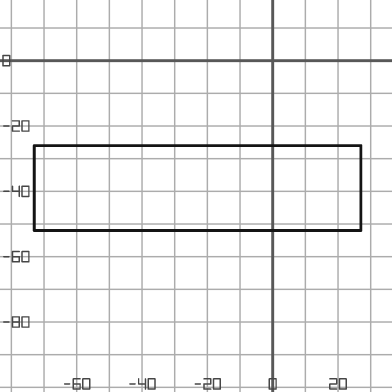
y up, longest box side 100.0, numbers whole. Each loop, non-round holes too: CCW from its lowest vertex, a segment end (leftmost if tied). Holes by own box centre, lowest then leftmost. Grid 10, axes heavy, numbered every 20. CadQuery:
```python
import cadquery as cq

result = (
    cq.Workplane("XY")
    .moveTo(-73.0, -52.0)
    .lineTo(27.0, -52.0)
    .lineTo(27.0, -26.0)
    .lineTo(-73.0, -26.0)
    .close()
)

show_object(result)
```